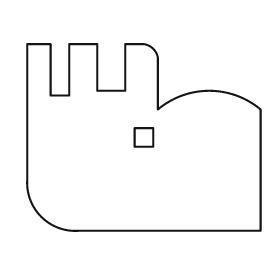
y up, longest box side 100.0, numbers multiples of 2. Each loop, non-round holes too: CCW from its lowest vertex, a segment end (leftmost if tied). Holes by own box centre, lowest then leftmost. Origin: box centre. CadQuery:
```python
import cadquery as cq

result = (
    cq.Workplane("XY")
    .moveTo(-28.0, -40.0)
    .lineTo(50.0, -40.0)
    .lineTo(50.0, 12.0)
    .threePointArc((28.0, 20.0), (6.0, 12.0))
    .lineTo(6.0, 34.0)
    .threePointArc((4.0, 38.0), (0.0, 40.0))
    .lineTo(-8.0, 40.0)
    .lineTo(-8.0, 20.0)
    .lineTo(-20.0, 20.0)
    .lineTo(-20.0, 40.0)
    .lineTo(-32.0, 40.0)
    .lineTo(-32.0, 18.0)
    .lineTo(-40.0, 18.0)
    .lineTo(-40.0, 40.0)
    .lineTo(-50.0, 40.0)
    .lineTo(-50.0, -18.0)
    .threePointArc((-44.0, -34.0), (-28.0, -40.0))
    .close()
    .moveTo(-4.0, -4.0)
    .lineTo(4.0, -4.0)
    .lineTo(4.0, 4.0)
    .lineTo(-4.0, 4.0)
    .close()
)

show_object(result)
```